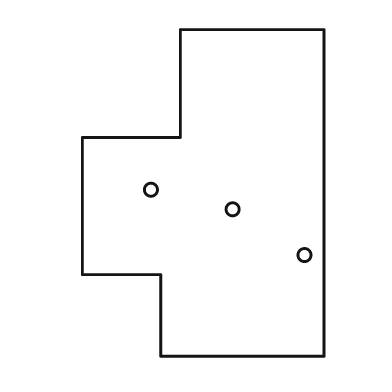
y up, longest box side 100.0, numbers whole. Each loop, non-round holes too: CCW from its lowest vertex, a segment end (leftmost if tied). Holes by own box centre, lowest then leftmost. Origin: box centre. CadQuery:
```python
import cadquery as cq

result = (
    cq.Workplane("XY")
    .moveTo(-13.0, -50.0)
    .lineTo(37.0, -50.0)
    .lineTo(37.0, 50.0)
    .lineTo(-7.0, 50.0)
    .lineTo(-7.0, 17.0)
    .lineTo(-37.0, 17.0)
    .lineTo(-37.0, -25.0)
    .lineTo(-13.0, -25.0)
    .close()
    .moveTo(31.0, -19.0)
    .circle(2.0)
    .moveTo(9.0, -5.0)
    .circle(2.0)
    .moveTo(-16.0, 1.0)
    .circle(2.0)
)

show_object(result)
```